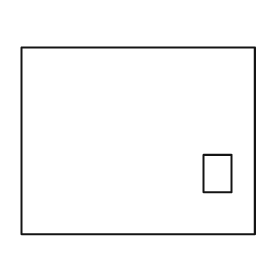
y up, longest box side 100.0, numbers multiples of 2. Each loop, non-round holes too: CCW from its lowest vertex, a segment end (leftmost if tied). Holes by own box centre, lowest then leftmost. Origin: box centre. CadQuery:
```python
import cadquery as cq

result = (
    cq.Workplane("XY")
    .moveTo(-50.0, -40.0)
    .lineTo(50.0, -40.0)
    .lineTo(50.0, 40.0)
    .lineTo(-50.0, 40.0)
    .close()
    .moveTo(28.0, -22.0)
    .lineTo(40.0, -22.0)
    .lineTo(40.0, -6.0)
    .lineTo(28.0, -6.0)
    .close()
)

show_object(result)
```